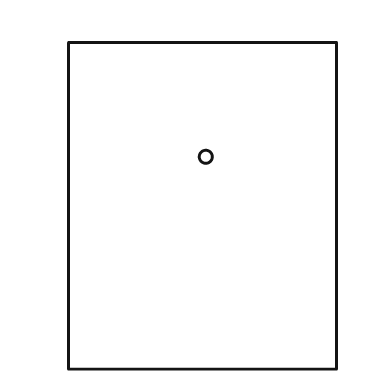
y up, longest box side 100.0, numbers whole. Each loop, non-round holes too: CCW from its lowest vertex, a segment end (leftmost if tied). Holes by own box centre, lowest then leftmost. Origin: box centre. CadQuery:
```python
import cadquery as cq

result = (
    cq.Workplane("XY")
    .moveTo(-41.0, -50.0)
    .lineTo(41.0, -50.0)
    .lineTo(41.0, 50.0)
    .lineTo(-41.0, 50.0)
    .close()
    .moveTo(1.0, 15.0)
    .circle(2.0)
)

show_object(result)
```